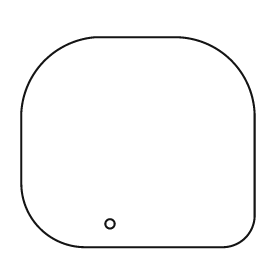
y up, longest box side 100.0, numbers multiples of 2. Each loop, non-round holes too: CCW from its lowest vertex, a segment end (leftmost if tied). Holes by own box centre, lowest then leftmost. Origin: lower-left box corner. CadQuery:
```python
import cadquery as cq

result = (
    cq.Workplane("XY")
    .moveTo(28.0, 0.0)
    .lineTo(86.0, 0.0)
    .threePointArc((96.0, 4.0), (100.0, 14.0))
    .lineTo(100.0, 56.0)
    .threePointArc((90.0, 80.0), (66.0, 90.0))
    .lineTo(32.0, 90.0)
    .threePointArc((10.0, 80.0), (0.0, 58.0))
    .lineTo(0.0, 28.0)
    .threePointArc((8.0, 8.0), (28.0, 0.0))
    .close()
    .moveTo(38.0, 10.0)
    .circle(2.0)
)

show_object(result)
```